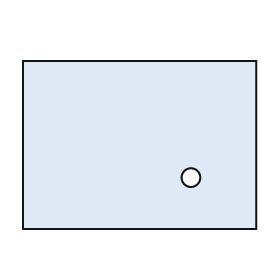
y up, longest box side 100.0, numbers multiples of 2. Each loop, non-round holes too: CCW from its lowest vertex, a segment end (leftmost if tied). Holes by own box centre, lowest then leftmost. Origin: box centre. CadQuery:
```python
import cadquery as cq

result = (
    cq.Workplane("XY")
    .moveTo(-50.0, -36.0)
    .lineTo(50.0, -36.0)
    .lineTo(50.0, 36.0)
    .lineTo(-50.0, 36.0)
    .close()
    .moveTo(22.0, -14.0)
    .circle(4.0)
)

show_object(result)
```